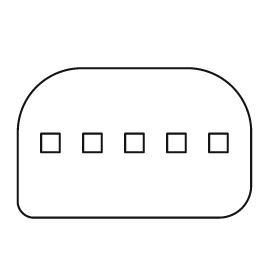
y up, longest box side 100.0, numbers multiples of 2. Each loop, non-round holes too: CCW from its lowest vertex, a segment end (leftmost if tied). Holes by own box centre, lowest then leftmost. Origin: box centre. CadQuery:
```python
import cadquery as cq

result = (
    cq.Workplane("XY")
    .moveTo(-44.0, -32.0)
    .lineTo(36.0, -32.0)
    .threePointArc((46.0, -28.0), (50.0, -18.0))
    .lineTo(50.0, 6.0)
    .threePointArc((42.0, 24.0), (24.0, 32.0))
    .lineTo(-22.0, 32.0)
    .threePointArc((-42.0, 24.0), (-50.0, 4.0))
    .lineTo(-50.0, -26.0)
    .threePointArc((-48.0, -30.0), (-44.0, -32.0))
    .close()
    .moveTo(-40.0, -4.0)
    .lineTo(-32.0, -4.0)
    .lineTo(-32.0, 4.0)
    .lineTo(-40.0, 4.0)
    .close()
    .moveTo(-22.0, -4.0)
    .lineTo(-14.0, -4.0)
    .lineTo(-14.0, 4.0)
    .lineTo(-22.0, 4.0)
    .close()
    .moveTo(-4.0, -4.0)
    .lineTo(4.0, -4.0)
    .lineTo(4.0, 4.0)
    .lineTo(-4.0, 4.0)
    .close()
    .moveTo(14.0, -4.0)
    .lineTo(22.0, -4.0)
    .lineTo(22.0, 4.0)
    .lineTo(14.0, 4.0)
    .close()
    .moveTo(32.0, -4.0)
    .lineTo(40.0, -4.0)
    .lineTo(40.0, 4.0)
    .lineTo(32.0, 4.0)
    .close()
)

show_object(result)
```